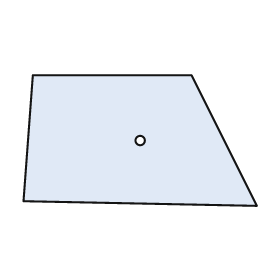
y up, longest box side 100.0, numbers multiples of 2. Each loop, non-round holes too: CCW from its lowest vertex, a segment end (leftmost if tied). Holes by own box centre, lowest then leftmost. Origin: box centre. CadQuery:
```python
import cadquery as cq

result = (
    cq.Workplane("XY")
    .moveTo(50.0, -28.0)
    .lineTo(22.0, 28.0)
    .lineTo(-46.0, 28.0)
    .lineTo(-50.0, -26.0)
    .close()
    .moveTo(0.0, 0.0)
    .circle(2.0)
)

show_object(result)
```